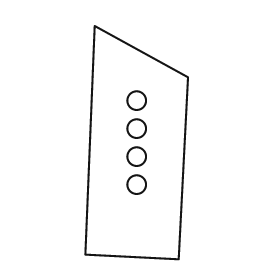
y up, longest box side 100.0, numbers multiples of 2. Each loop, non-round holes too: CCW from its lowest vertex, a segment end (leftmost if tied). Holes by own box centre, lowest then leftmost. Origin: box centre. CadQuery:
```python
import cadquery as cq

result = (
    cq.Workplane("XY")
    .moveTo(18.0, -50.0)
    .lineTo(22.0, 28.0)
    .lineTo(-18.0, 50.0)
    .lineTo(-22.0, -48.0)
    .close()
    .moveTo(0.0, -18.0)
    .circle(4.0)
    .moveTo(0.0, -6.0)
    .circle(4.0)
    .moveTo(0.0, 6.0)
    .circle(4.0)
    .moveTo(0.0, 18.0)
    .circle(4.0)
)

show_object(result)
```